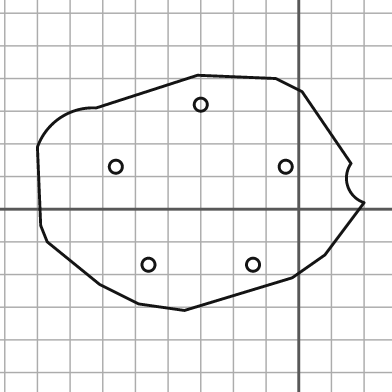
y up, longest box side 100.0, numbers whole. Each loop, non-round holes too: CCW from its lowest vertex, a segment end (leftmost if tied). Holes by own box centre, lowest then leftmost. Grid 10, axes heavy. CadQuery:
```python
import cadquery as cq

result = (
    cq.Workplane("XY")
    .moveTo(-35.0, -31.0)
    .lineTo(-2.0, -21.0)
    .lineTo(8.0, -14.0)
    .lineTo(20.0, 2.0)
    .threePointArc((15.0, 7.0), (16.0, 14.0))
    .lineTo(1.0, 36.0)
    .lineTo(-7.0, 40.0)
    .lineTo(-31.0, 41.0)
    .lineTo(-62.0, 31.0)
    .threePointArc((-73.0, 28.0), (-80.0, 19.0))
    .lineTo(-79.0, -5.0)
    .lineTo(-77.0, -10.0)
    .lineTo(-61.0, -23.0)
    .lineTo(-49.0, -29.0)
    .close()
    .moveTo(-46.0, -17.0)
    .circle(2.0)
    .moveTo(-14.0, -17.0)
    .circle(2.0)
    .moveTo(-56.0, 13.0)
    .circle(2.0)
    .moveTo(-4.0, 13.0)
    .circle(2.0)
    .moveTo(-30.0, 32.0)
    .circle(2.0)
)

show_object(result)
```